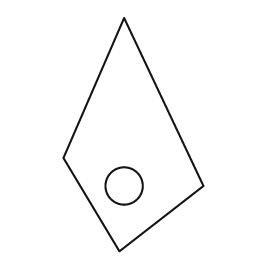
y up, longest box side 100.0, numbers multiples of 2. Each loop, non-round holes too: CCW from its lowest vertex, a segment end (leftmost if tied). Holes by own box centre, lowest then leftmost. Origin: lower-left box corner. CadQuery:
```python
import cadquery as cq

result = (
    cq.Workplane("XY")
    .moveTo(24.0, 0.0)
    .lineTo(60.0, 28.0)
    .lineTo(26.0, 100.0)
    .lineTo(0.0, 40.0)
    .close()
    .moveTo(26.0, 28.0)
    .circle(8.0)
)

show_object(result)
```